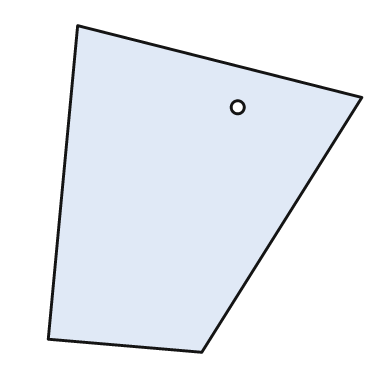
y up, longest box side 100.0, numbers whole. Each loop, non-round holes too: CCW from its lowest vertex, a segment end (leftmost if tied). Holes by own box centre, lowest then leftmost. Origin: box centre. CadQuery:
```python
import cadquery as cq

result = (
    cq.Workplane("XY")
    .moveTo(-1.0, -50.0)
    .lineTo(48.0, 28.0)
    .lineTo(-39.0, 50.0)
    .lineTo(-48.0, -46.0)
    .close()
    .moveTo(10.0, 25.0)
    .circle(2.0)
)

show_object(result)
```